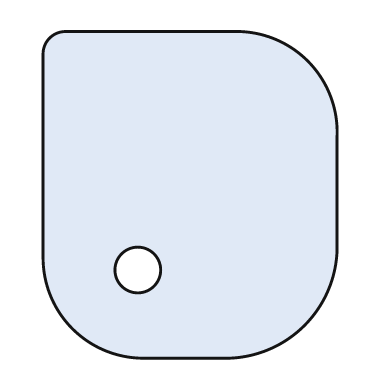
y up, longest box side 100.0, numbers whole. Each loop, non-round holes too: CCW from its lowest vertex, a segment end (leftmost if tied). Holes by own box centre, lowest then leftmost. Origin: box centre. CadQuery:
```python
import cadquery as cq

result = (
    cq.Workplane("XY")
    .moveTo(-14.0, -50.0)
    .lineTo(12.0, -50.0)
    .threePointArc((35.0, -40.0), (45.0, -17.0))
    .lineTo(45.0, 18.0)
    .threePointArc((36.0, 41.0), (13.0, 50.0))
    .lineTo(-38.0, 50.0)
    .threePointArc((-43.0, 48.0), (-45.0, 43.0))
    .lineTo(-45.0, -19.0)
    .threePointArc((-36.0, -41.0), (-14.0, -50.0))
    .close()
    .moveTo(-16.0, -23.0)
    .circle(7.0)
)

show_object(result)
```